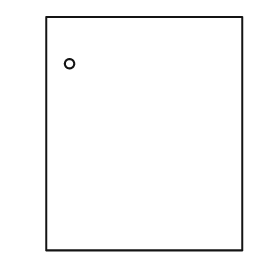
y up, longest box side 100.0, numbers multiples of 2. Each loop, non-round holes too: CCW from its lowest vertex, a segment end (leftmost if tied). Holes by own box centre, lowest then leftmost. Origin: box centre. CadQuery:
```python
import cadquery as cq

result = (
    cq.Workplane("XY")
    .moveTo(-42.0, -50.0)
    .lineTo(42.0, -50.0)
    .lineTo(42.0, 50.0)
    .lineTo(-42.0, 50.0)
    .close()
    .moveTo(-32.0, 30.0)
    .circle(2.0)
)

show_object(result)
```